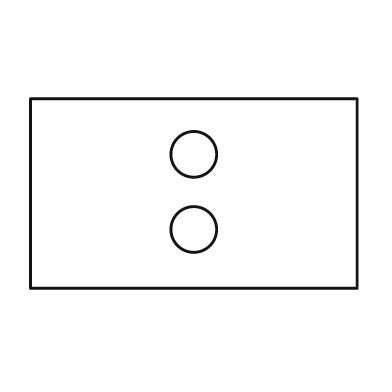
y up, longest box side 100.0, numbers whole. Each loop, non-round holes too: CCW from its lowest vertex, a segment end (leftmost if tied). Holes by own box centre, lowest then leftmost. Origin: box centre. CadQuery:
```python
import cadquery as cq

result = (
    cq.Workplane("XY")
    .moveTo(-50.0, -29.0)
    .lineTo(50.0, -29.0)
    .lineTo(50.0, 29.0)
    .lineTo(-50.0, 29.0)
    .close()
    .moveTo(0.0, -11.0)
    .circle(7.0)
    .moveTo(0.0, 12.0)
    .circle(7.0)
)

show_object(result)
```